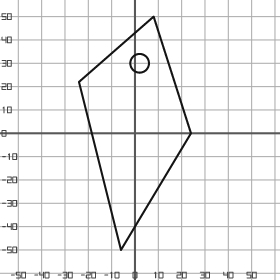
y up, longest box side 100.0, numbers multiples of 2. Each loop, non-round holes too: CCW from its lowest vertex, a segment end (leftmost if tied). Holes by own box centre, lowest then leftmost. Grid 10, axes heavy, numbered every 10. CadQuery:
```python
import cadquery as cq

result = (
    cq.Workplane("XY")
    .moveTo(-6.0, -50.0)
    .lineTo(24.0, 0.0)
    .lineTo(8.0, 50.0)
    .lineTo(-24.0, 22.0)
    .close()
    .moveTo(2.0, 30.0)
    .circle(4.0)
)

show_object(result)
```